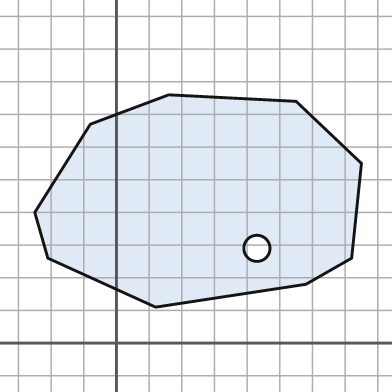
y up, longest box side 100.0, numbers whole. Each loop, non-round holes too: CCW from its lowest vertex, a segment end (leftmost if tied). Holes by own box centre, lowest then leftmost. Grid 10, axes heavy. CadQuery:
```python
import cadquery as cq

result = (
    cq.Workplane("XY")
    .moveTo(12.0, 11.0)
    .lineTo(58.0, 18.0)
    .lineTo(72.0, 26.0)
    .lineTo(75.0, 55.0)
    .lineTo(55.0, 74.0)
    .lineTo(16.0, 76.0)
    .lineTo(-8.0, 67.0)
    .lineTo(-25.0, 40.0)
    .lineTo(-21.0, 26.0)
    .close()
    .moveTo(43.0, 29.0)
    .circle(4.0)
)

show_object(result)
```